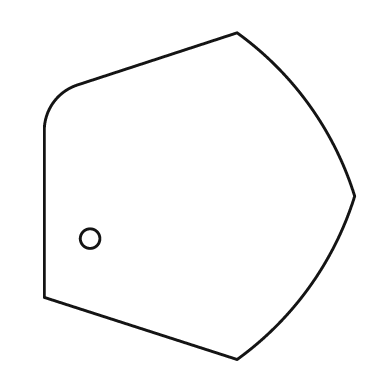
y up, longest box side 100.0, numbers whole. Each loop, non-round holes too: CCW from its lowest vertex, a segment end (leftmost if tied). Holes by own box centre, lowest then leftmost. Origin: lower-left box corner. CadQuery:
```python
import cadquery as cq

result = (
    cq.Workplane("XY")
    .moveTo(59.0, 0.0)
    .threePointArc((81.0, 22.0), (95.0, 50.0))
    .threePointArc((81.0, 78.0), (59.0, 100.0))
    .lineTo(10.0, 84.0)
    .threePointArc((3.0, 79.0), (0.0, 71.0))
    .lineTo(0.0, 19.0)
    .close()
    .moveTo(14.0, 37.0)
    .circle(3.0)
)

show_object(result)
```